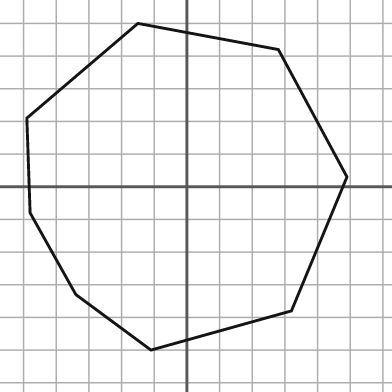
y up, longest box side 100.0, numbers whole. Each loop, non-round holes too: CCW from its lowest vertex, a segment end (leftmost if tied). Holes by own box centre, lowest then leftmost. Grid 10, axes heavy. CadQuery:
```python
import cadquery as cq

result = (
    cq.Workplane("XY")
    .moveTo(-11.0, -50.0)
    .lineTo(32.0, -38.0)
    .lineTo(49.0, 3.0)
    .lineTo(28.0, 42.0)
    .lineTo(-15.0, 50.0)
    .lineTo(-49.0, 21.0)
    .lineTo(-48.0, -8.0)
    .lineTo(-34.0, -33.0)
    .close()
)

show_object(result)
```